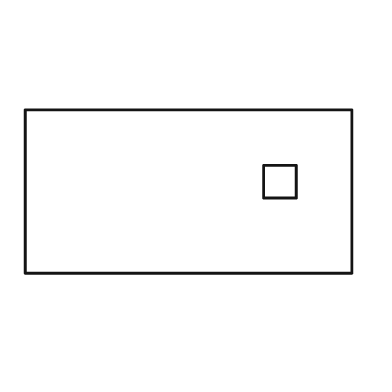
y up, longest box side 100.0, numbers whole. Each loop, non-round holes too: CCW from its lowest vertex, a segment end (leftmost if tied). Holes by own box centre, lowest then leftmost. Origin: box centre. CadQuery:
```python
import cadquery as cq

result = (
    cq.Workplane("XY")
    .moveTo(-50.0, -25.0)
    .lineTo(50.0, -25.0)
    .lineTo(50.0, 25.0)
    .lineTo(-50.0, 25.0)
    .close()
    .moveTo(23.0, -2.0)
    .lineTo(33.0, -2.0)
    .lineTo(33.0, 8.0)
    .lineTo(23.0, 8.0)
    .close()
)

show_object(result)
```